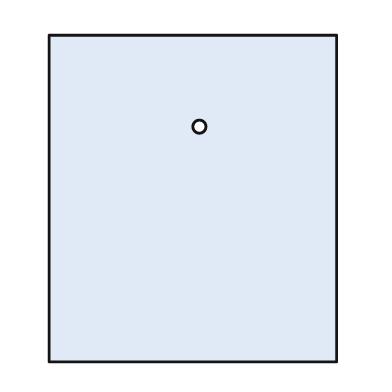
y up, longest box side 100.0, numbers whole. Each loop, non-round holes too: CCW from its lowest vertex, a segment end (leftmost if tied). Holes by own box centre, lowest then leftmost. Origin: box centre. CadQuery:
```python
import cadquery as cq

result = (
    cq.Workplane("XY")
    .moveTo(-44.0, -50.0)
    .lineTo(44.0, -50.0)
    .lineTo(44.0, 50.0)
    .lineTo(-44.0, 50.0)
    .close()
    .moveTo(2.0, 22.0)
    .circle(2.0)
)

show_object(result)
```